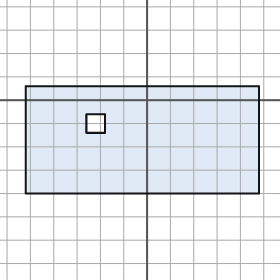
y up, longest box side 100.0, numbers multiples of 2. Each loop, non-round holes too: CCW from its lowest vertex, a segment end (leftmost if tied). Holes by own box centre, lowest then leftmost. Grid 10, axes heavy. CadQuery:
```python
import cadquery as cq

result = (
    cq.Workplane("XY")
    .moveTo(-52.0, -40.0)
    .lineTo(48.0, -40.0)
    .lineTo(48.0, 6.0)
    .lineTo(-52.0, 6.0)
    .close()
    .moveTo(-26.0, -14.0)
    .lineTo(-18.0, -14.0)
    .lineTo(-18.0, -6.0)
    .lineTo(-26.0, -6.0)
    .close()
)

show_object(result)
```